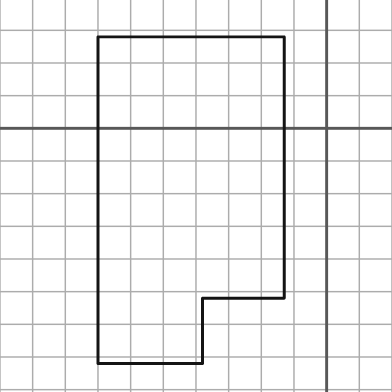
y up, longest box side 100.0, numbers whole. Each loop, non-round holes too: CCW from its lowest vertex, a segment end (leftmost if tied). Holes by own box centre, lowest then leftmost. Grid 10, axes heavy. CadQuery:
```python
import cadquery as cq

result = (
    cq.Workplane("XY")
    .moveTo(-70.0, -72.0)
    .lineTo(-38.0, -72.0)
    .lineTo(-38.0, -52.0)
    .lineTo(-13.0, -52.0)
    .lineTo(-13.0, 28.0)
    .lineTo(-70.0, 28.0)
    .close()
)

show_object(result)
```